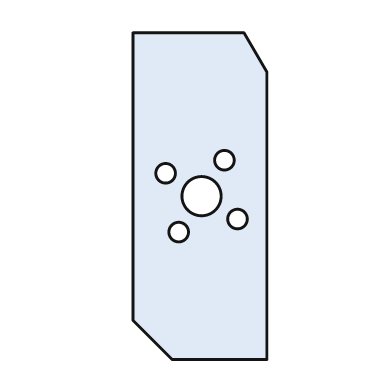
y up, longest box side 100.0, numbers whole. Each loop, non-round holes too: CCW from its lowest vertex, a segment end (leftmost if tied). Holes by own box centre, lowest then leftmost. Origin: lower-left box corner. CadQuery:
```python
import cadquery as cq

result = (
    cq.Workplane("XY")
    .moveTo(12.0, 0.0)
    .lineTo(41.0, 0.0)
    .lineTo(41.0, 88.0)
    .lineTo(34.0, 100.0)
    .lineTo(0.0, 100.0)
    .lineTo(0.0, 12.0)
    .close()
    .moveTo(14.0, 39.0)
    .circle(3.0)
    .moveTo(32.0, 43.0)
    .circle(3.0)
    .moveTo(21.0, 50.0)
    .circle(6.0)
    .moveTo(10.0, 57.0)
    .circle(3.0)
    .moveTo(28.0, 61.0)
    .circle(3.0)
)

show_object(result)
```